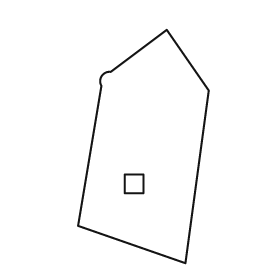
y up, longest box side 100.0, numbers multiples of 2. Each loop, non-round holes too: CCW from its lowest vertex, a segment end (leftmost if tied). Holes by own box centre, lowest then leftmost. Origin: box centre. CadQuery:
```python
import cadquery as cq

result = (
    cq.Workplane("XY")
    .moveTo(18.0, -50.0)
    .lineTo(28.0, 24.0)
    .lineTo(10.0, 50.0)
    .lineTo(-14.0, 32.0)
    .threePointArc((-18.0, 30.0), (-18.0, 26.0))
    .lineTo(-28.0, -34.0)
    .close()
    .moveTo(-8.0, -20.0)
    .lineTo(0.0, -20.0)
    .lineTo(0.0, -12.0)
    .lineTo(-8.0, -12.0)
    .close()
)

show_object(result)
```